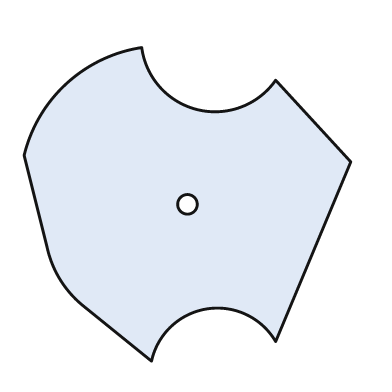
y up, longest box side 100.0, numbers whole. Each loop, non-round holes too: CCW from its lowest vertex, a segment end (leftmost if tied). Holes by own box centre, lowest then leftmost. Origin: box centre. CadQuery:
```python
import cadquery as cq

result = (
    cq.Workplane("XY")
    .moveTo(-11.0, -48.0)
    .threePointArc((6.0, -32.0), (27.0, -42.0))
    .lineTo(50.0, 13.0)
    .lineTo(27.0, 38.0)
    .threePointArc((3.0, 29.0), (-14.0, 48.0))
    .threePointArc((-37.0, 37.0), (-50.0, 15.0))
    .lineTo(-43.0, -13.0)
    .threePointArc((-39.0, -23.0), (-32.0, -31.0))
    .close()
    .moveTo(0.0, 0.0)
    .circle(3.0)
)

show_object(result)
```